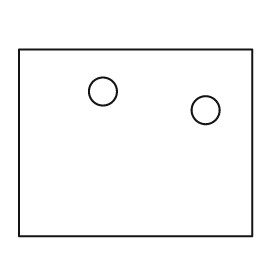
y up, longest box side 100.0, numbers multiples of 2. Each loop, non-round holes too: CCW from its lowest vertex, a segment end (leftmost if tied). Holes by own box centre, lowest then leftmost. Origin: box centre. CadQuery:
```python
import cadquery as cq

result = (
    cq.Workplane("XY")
    .moveTo(-50.0, -40.0)
    .lineTo(50.0, -40.0)
    .lineTo(50.0, 40.0)
    .lineTo(-50.0, 40.0)
    .close()
    .moveTo(30.0, 14.0)
    .circle(6.0)
    .moveTo(-14.0, 22.0)
    .circle(6.0)
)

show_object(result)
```